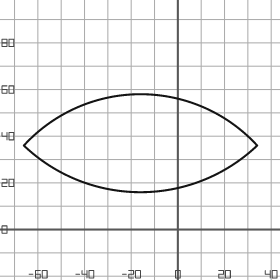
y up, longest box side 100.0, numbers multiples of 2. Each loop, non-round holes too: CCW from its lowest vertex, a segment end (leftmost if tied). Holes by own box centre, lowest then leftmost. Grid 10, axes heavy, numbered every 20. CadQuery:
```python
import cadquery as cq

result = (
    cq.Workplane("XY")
    .moveTo(-66.0, 36.0)
    .threePointArc((-16.0, 16.0), (34.0, 36.0))
    .threePointArc((-16.0, 58.0), (-66.0, 36.0))
    .close()
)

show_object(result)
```